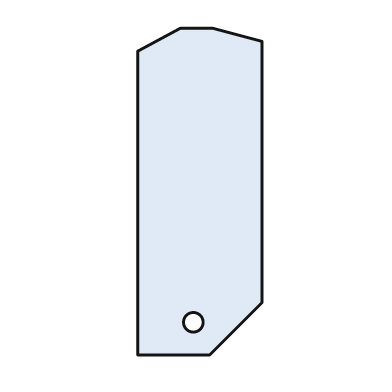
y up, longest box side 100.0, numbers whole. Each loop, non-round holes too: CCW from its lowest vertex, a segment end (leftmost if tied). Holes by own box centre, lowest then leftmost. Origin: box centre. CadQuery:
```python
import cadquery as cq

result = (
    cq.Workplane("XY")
    .moveTo(-19.0, -50.0)
    .lineTo(3.0, -50.0)
    .lineTo(19.0, -34.0)
    .lineTo(19.0, 46.0)
    .lineTo(4.0, 50.0)
    .lineTo(-6.0, 50.0)
    .lineTo(-19.0, 43.0)
    .close()
    .moveTo(-2.0, -40.0)
    .circle(3.0)
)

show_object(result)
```